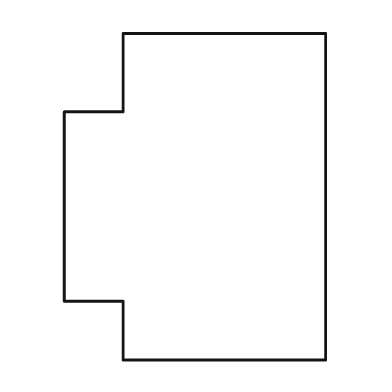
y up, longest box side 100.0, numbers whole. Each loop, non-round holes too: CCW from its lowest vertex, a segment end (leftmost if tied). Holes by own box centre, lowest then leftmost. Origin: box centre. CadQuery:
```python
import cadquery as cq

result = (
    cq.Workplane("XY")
    .moveTo(-22.0, -50.0)
    .lineTo(40.0, -50.0)
    .lineTo(40.0, 50.0)
    .lineTo(-22.0, 50.0)
    .lineTo(-22.0, 26.0)
    .lineTo(-40.0, 26.0)
    .lineTo(-40.0, -32.0)
    .lineTo(-22.0, -32.0)
    .close()
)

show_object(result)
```